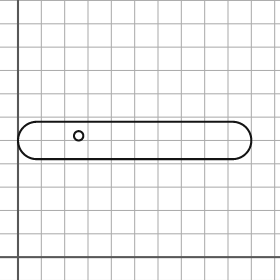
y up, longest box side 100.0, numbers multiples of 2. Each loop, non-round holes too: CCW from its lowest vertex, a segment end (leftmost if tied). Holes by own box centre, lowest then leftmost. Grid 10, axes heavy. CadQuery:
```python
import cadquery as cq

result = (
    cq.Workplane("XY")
    .moveTo(8.0, 42.0)
    .lineTo(92.0, 42.0)
    .threePointArc((100.0, 50.0), (92.0, 58.0))
    .lineTo(8.0, 58.0)
    .threePointArc((0.0, 50.0), (8.0, 42.0))
    .close()
    .moveTo(26.0, 52.0)
    .circle(2.0)
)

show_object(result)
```